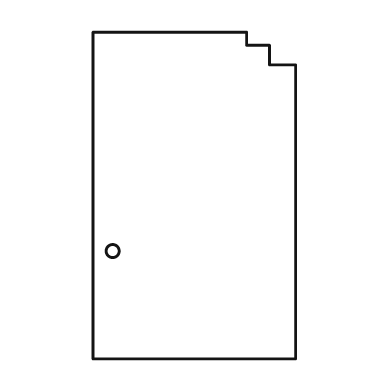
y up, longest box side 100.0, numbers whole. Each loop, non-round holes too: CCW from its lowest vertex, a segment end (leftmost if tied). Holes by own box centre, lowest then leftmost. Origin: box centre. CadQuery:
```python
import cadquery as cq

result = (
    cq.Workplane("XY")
    .moveTo(-31.0, -50.0)
    .lineTo(31.0, -50.0)
    .lineTo(31.0, 40.0)
    .lineTo(23.0, 40.0)
    .lineTo(23.0, 46.0)
    .lineTo(16.0, 46.0)
    .lineTo(16.0, 50.0)
    .lineTo(-31.0, 50.0)
    .close()
    .moveTo(-25.0, -17.0)
    .circle(2.0)
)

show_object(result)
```